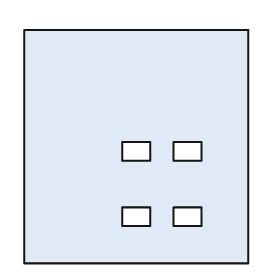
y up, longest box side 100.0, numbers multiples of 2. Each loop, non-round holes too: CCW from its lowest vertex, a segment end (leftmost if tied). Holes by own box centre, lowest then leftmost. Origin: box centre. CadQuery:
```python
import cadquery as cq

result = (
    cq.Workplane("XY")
    .moveTo(-48.0, -50.0)
    .lineTo(48.0, -50.0)
    .lineTo(48.0, 50.0)
    .lineTo(-48.0, 50.0)
    .close()
    .moveTo(-6.0, -34.0)
    .lineTo(6.0, -34.0)
    .lineTo(6.0, -26.0)
    .lineTo(-6.0, -26.0)
    .close()
    .moveTo(16.0, -34.0)
    .lineTo(28.0, -34.0)
    .lineTo(28.0, -26.0)
    .lineTo(16.0, -26.0)
    .close()
    .moveTo(-6.0, -6.0)
    .lineTo(6.0, -6.0)
    .lineTo(6.0, 2.0)
    .lineTo(-6.0, 2.0)
    .close()
    .moveTo(16.0, -6.0)
    .lineTo(28.0, -6.0)
    .lineTo(28.0, 2.0)
    .lineTo(16.0, 2.0)
    .close()
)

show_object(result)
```